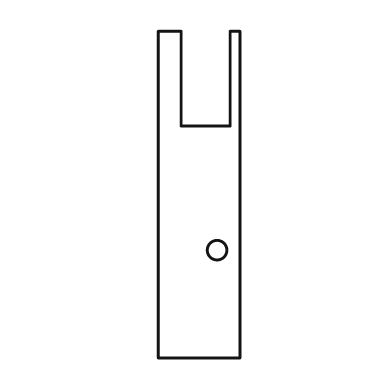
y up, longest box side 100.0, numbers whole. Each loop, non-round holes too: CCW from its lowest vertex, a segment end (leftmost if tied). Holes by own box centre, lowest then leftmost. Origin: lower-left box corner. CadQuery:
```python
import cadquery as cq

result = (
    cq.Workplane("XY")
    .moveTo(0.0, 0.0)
    .lineTo(25.0, 0.0)
    .lineTo(25.0, 100.0)
    .lineTo(22.0, 100.0)
    .lineTo(22.0, 71.0)
    .lineTo(7.0, 71.0)
    .lineTo(7.0, 100.0)
    .lineTo(0.0, 100.0)
    .close()
    .moveTo(18.0, 33.0)
    .circle(3.0)
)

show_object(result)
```